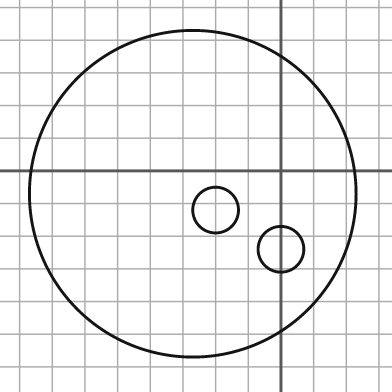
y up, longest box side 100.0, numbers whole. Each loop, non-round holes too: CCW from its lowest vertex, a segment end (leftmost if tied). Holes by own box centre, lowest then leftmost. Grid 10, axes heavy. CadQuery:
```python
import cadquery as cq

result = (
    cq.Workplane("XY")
    .moveTo(-27.0, -7.0)
    .circle(50.0)
    .moveTo(0.0, -24.0)
    .circle(7.0)
    .moveTo(-20.0, -12.0)
    .circle(7.0)
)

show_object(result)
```